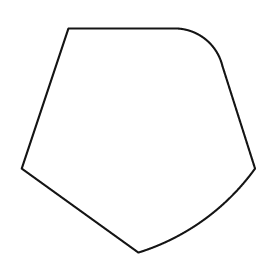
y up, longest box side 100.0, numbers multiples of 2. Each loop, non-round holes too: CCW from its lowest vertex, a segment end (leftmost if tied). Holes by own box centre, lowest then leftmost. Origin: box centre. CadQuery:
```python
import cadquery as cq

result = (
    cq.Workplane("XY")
    .moveTo(0.0, -48.0)
    .threePointArc((28.0, -34.0), (50.0, -12.0))
    .lineTo(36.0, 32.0)
    .threePointArc((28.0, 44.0), (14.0, 48.0))
    .lineTo(-30.0, 48.0)
    .lineTo(-50.0, -12.0)
    .close()
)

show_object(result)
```